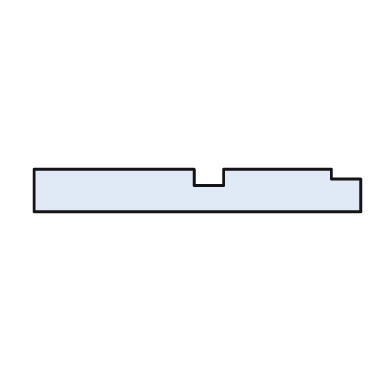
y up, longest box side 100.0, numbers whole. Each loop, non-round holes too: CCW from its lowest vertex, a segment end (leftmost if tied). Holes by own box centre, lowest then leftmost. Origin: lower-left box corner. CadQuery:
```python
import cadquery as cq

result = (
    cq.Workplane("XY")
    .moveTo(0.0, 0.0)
    .lineTo(100.0, 0.0)
    .lineTo(100.0, 10.0)
    .lineTo(91.0, 10.0)
    .lineTo(91.0, 13.0)
    .lineTo(58.0, 13.0)
    .lineTo(58.0, 8.0)
    .lineTo(49.0, 8.0)
    .lineTo(49.0, 13.0)
    .lineTo(0.0, 13.0)
    .close()
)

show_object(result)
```